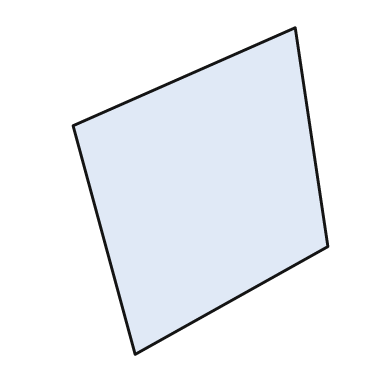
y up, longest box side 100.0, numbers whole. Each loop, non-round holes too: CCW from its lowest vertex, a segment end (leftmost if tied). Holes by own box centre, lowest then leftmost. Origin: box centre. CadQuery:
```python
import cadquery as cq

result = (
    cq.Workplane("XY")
    .moveTo(-20.0, -50.0)
    .lineTo(39.0, -17.0)
    .lineTo(29.0, 50.0)
    .lineTo(-39.0, 20.0)
    .close()
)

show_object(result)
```